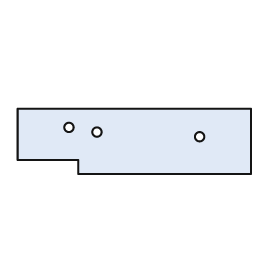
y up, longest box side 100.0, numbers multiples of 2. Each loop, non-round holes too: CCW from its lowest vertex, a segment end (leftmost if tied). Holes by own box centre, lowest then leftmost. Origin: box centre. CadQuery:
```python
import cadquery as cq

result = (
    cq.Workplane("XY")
    .moveTo(-24.0, -14.0)
    .lineTo(50.0, -14.0)
    .lineTo(50.0, 14.0)
    .lineTo(-50.0, 14.0)
    .lineTo(-50.0, -8.0)
    .lineTo(-24.0, -8.0)
    .close()
    .moveTo(28.0, 2.0)
    .circle(2.0)
    .moveTo(-16.0, 4.0)
    .circle(2.0)
    .moveTo(-28.0, 6.0)
    .circle(2.0)
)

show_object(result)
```